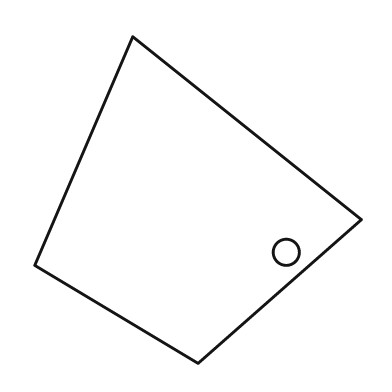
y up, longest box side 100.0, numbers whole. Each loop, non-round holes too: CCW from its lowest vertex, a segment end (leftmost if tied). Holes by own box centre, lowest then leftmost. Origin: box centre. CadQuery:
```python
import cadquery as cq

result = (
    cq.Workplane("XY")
    .moveTo(0.0, -50.0)
    .lineTo(50.0, -6.0)
    .lineTo(-20.0, 50.0)
    .lineTo(-50.0, -20.0)
    .close()
    .moveTo(27.0, -16.0)
    .circle(4.0)
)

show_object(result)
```